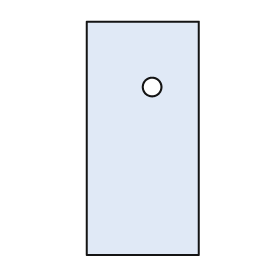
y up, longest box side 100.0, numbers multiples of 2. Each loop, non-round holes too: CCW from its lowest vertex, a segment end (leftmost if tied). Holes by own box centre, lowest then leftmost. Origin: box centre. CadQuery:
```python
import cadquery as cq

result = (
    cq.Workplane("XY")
    .moveTo(-24.0, -50.0)
    .lineTo(24.0, -50.0)
    .lineTo(24.0, 50.0)
    .lineTo(-24.0, 50.0)
    .close()
    .moveTo(4.0, 22.0)
    .circle(4.0)
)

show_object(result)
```